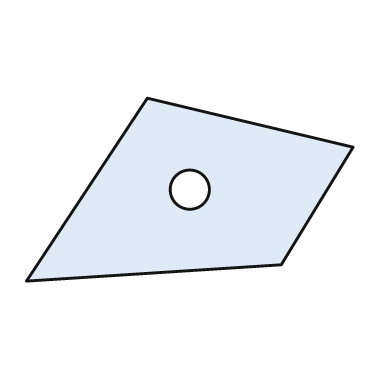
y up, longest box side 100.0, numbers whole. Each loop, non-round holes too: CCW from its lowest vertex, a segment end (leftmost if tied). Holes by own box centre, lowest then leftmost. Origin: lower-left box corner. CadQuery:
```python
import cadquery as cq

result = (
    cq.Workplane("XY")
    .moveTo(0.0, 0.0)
    .lineTo(78.0, 5.0)
    .lineTo(100.0, 41.0)
    .lineTo(37.0, 56.0)
    .close()
    .moveTo(50.0, 28.0)
    .circle(6.0)
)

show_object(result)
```